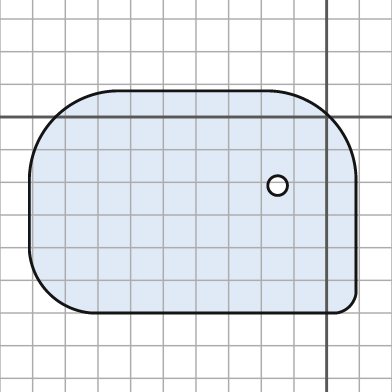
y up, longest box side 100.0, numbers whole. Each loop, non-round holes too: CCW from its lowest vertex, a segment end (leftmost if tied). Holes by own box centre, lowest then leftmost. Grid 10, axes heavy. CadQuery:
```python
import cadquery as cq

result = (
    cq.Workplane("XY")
    .moveTo(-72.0, -60.0)
    .lineTo(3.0, -60.0)
    .threePointArc((7.0, -58.0), (9.0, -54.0))
    .lineTo(9.0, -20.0)
    .threePointArc((1.0, 0.0), (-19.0, 8.0))
    .lineTo(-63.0, 8.0)
    .threePointArc((-83.0, 0.0), (-91.0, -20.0))
    .lineTo(-91.0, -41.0)
    .threePointArc((-85.0, -54.0), (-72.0, -60.0))
    .close()
    .moveTo(-15.0, -21.0)
    .circle(3.0)
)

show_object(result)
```